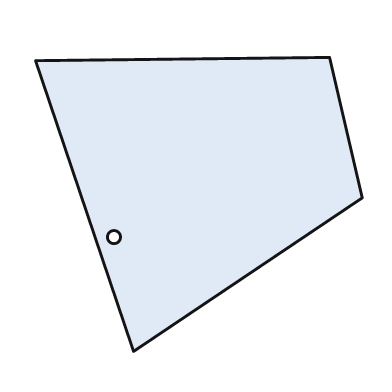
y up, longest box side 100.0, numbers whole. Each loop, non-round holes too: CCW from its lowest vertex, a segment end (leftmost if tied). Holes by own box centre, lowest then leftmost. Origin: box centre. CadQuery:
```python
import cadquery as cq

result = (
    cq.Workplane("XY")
    .moveTo(-20.0, -45.0)
    .lineTo(50.0, 2.0)
    .lineTo(40.0, 45.0)
    .lineTo(-50.0, 44.0)
    .close()
    .moveTo(-26.0, -10.0)
    .circle(2.0)
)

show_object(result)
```